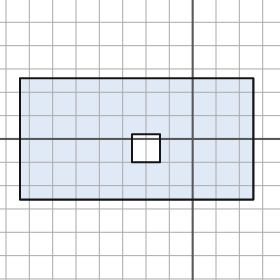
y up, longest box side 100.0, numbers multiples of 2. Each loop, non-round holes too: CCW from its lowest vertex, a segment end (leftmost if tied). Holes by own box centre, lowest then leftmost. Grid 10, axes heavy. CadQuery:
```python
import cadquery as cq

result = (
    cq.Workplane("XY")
    .moveTo(-74.0, -26.0)
    .lineTo(26.0, -26.0)
    .lineTo(26.0, 26.0)
    .lineTo(-74.0, 26.0)
    .close()
    .moveTo(-26.0, -10.0)
    .lineTo(-14.0, -10.0)
    .lineTo(-14.0, 2.0)
    .lineTo(-26.0, 2.0)
    .close()
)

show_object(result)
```